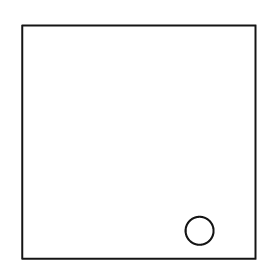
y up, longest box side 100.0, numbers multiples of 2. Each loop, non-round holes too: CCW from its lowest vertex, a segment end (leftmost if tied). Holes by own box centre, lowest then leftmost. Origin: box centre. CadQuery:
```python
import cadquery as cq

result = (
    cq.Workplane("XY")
    .moveTo(-50.0, -50.0)
    .lineTo(50.0, -50.0)
    .lineTo(50.0, 50.0)
    .lineTo(-50.0, 50.0)
    .close()
    .moveTo(26.0, -38.0)
    .circle(6.0)
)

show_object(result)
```